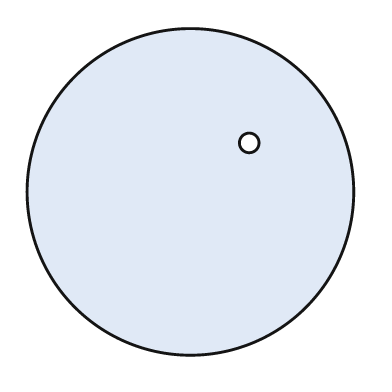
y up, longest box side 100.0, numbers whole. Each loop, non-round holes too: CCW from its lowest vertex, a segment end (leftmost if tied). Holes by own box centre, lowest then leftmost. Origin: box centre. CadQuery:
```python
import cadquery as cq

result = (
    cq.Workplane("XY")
    .moveTo(0.0, 0.0)
    .circle(50.0)
    .moveTo(18.0, 15.0)
    .circle(3.0)
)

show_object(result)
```